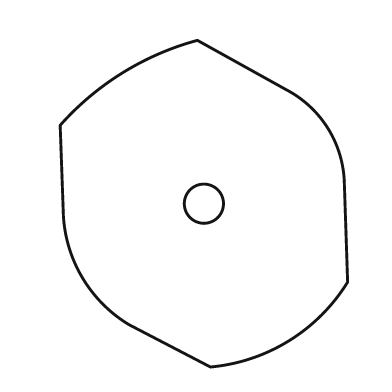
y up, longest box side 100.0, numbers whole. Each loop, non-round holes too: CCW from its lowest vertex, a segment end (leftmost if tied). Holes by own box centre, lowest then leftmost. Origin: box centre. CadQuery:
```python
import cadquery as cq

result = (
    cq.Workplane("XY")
    .moveTo(2.0, -50.0)
    .threePointArc((26.0, -42.0), (44.0, -24.0))
    .lineTo(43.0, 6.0)
    .threePointArc((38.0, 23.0), (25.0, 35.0))
    .lineTo(-2.0, 50.0)
    .threePointArc((-25.0, 40.0), (-44.0, 24.0))
    .lineTo(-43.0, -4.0)
    .threePointArc((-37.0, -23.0), (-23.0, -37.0))
    .close()
    .moveTo(0.0, 0.0)
    .circle(6.0)
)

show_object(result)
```